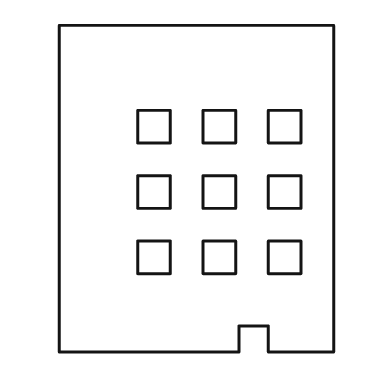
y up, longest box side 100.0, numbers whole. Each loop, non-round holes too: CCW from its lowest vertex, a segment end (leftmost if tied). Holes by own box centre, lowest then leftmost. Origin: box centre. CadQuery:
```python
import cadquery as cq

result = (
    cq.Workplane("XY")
    .moveTo(-42.0, -50.0)
    .lineTo(13.0, -50.0)
    .lineTo(13.0, -42.0)
    .lineTo(22.0, -42.0)
    .lineTo(22.0, -50.0)
    .lineTo(42.0, -50.0)
    .lineTo(42.0, 50.0)
    .lineTo(-42.0, 50.0)
    .close()
    .moveTo(-18.0, -26.0)
    .lineTo(-8.0, -26.0)
    .lineTo(-8.0, -16.0)
    .lineTo(-18.0, -16.0)
    .close()
    .moveTo(2.0, -26.0)
    .lineTo(12.0, -26.0)
    .lineTo(12.0, -16.0)
    .lineTo(2.0, -16.0)
    .close()
    .moveTo(22.0, -26.0)
    .lineTo(32.0, -26.0)
    .lineTo(32.0, -16.0)
    .lineTo(22.0, -16.0)
    .close()
    .moveTo(-18.0, -6.0)
    .lineTo(-8.0, -6.0)
    .lineTo(-8.0, 4.0)
    .lineTo(-18.0, 4.0)
    .close()
    .moveTo(2.0, -6.0)
    .lineTo(12.0, -6.0)
    .lineTo(12.0, 4.0)
    .lineTo(2.0, 4.0)
    .close()
    .moveTo(22.0, -6.0)
    .lineTo(32.0, -6.0)
    .lineTo(32.0, 4.0)
    .lineTo(22.0, 4.0)
    .close()
    .moveTo(-18.0, 14.0)
    .lineTo(-8.0, 14.0)
    .lineTo(-8.0, 24.0)
    .lineTo(-18.0, 24.0)
    .close()
    .moveTo(2.0, 14.0)
    .lineTo(12.0, 14.0)
    .lineTo(12.0, 24.0)
    .lineTo(2.0, 24.0)
    .close()
    .moveTo(22.0, 14.0)
    .lineTo(32.0, 14.0)
    .lineTo(32.0, 24.0)
    .lineTo(22.0, 24.0)
    .close()
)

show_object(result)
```